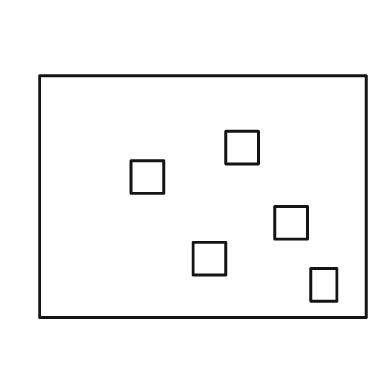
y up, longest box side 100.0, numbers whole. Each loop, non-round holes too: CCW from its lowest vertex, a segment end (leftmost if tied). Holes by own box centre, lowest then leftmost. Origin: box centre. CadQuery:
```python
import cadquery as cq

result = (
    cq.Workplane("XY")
    .moveTo(-50.0, -37.0)
    .lineTo(50.0, -37.0)
    .lineTo(50.0, 37.0)
    .lineTo(-50.0, 37.0)
    .close()
    .moveTo(33.0, -32.0)
    .lineTo(41.0, -32.0)
    .lineTo(41.0, -22.0)
    .lineTo(33.0, -22.0)
    .close()
    .moveTo(-3.0, -24.0)
    .lineTo(7.0, -24.0)
    .lineTo(7.0, -14.0)
    .lineTo(-3.0, -14.0)
    .close()
    .moveTo(22.0, -13.0)
    .lineTo(32.0, -13.0)
    .lineTo(32.0, -3.0)
    .lineTo(22.0, -3.0)
    .close()
    .moveTo(-22.0, 1.0)
    .lineTo(-12.0, 1.0)
    .lineTo(-12.0, 11.0)
    .lineTo(-22.0, 11.0)
    .close()
    .moveTo(7.0, 10.0)
    .lineTo(17.0, 10.0)
    .lineTo(17.0, 20.0)
    .lineTo(7.0, 20.0)
    .close()
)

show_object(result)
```